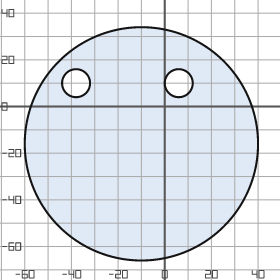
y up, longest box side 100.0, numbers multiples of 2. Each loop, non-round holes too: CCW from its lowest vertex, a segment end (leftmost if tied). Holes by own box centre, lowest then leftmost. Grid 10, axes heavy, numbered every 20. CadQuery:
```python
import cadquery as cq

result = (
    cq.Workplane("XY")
    .moveTo(-10.0, -16.0)
    .circle(50.0)
    .moveTo(-38.0, 10.0)
    .circle(6.0)
    .moveTo(6.0, 10.0)
    .circle(6.0)
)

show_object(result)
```